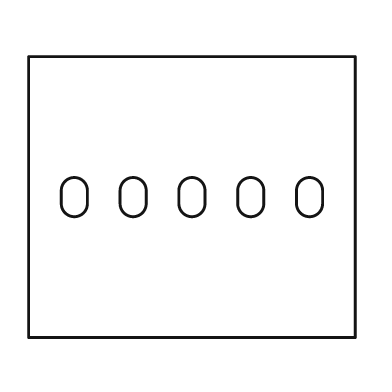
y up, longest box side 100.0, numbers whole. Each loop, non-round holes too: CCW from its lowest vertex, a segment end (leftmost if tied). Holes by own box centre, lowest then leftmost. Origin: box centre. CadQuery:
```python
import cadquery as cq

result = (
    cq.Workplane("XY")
    .moveTo(-50.0, -43.0)
    .lineTo(50.0, -43.0)
    .lineTo(50.0, 43.0)
    .lineTo(-50.0, 43.0)
    .close()
    .moveTo(-40.0, -2.0)
    .threePointArc((-36.0, -6.0), (-32.0, -2.0))
    .lineTo(-32.0, 2.0)
    .threePointArc((-36.0, 6.0), (-40.0, 2.0))
    .close()
    .moveTo(-22.0, -2.0)
    .threePointArc((-18.0, -6.0), (-14.0, -2.0))
    .lineTo(-14.0, 2.0)
    .threePointArc((-18.0, 6.0), (-22.0, 2.0))
    .close()
    .moveTo(-4.0, -2.0)
    .threePointArc((0.0, -6.0), (4.0, -2.0))
    .lineTo(4.0, 2.0)
    .threePointArc((0.0, 6.0), (-4.0, 2.0))
    .close()
    .moveTo(14.0, -2.0)
    .threePointArc((18.0, -6.0), (22.0, -2.0))
    .lineTo(22.0, 2.0)
    .threePointArc((18.0, 6.0), (14.0, 2.0))
    .close()
    .moveTo(32.0, -2.0)
    .threePointArc((36.0, -6.0), (40.0, -2.0))
    .lineTo(40.0, 2.0)
    .threePointArc((36.0, 6.0), (32.0, 2.0))
    .close()
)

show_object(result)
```